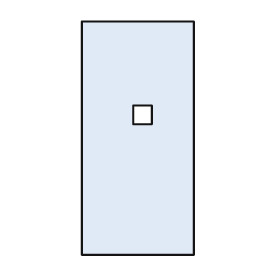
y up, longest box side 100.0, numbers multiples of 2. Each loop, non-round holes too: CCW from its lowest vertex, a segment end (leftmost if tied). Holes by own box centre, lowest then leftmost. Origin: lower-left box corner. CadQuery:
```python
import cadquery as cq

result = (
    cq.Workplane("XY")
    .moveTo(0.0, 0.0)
    .lineTo(48.0, 0.0)
    .lineTo(48.0, 100.0)
    .lineTo(0.0, 100.0)
    .close()
    .moveTo(22.0, 56.0)
    .lineTo(30.0, 56.0)
    .lineTo(30.0, 64.0)
    .lineTo(22.0, 64.0)
    .close()
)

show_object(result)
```